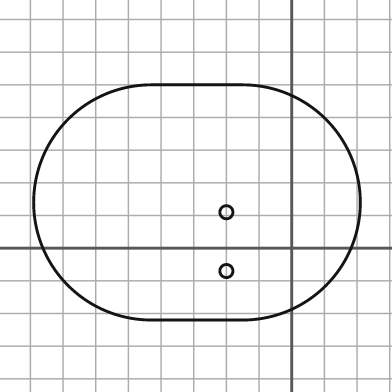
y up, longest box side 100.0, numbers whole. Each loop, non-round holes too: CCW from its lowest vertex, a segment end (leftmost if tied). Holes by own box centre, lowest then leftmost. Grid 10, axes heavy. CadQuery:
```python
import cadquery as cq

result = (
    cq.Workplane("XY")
    .moveTo(-43.0, -22.0)
    .lineTo(-15.0, -22.0)
    .threePointArc((21.0, 14.0), (-15.0, 50.0))
    .lineTo(-43.0, 50.0)
    .threePointArc((-79.0, 14.0), (-43.0, -22.0))
    .close()
    .moveTo(-20.0, -7.0)
    .circle(2.0)
    .moveTo(-20.0, 11.0)
    .circle(2.0)
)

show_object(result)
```